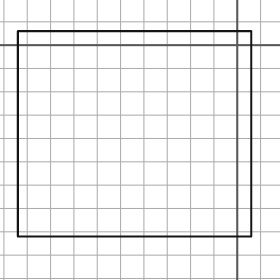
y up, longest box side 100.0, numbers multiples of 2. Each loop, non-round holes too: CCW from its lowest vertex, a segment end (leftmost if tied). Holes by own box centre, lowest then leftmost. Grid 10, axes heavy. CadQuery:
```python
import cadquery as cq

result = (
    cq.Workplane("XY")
    .moveTo(-94.0, -82.0)
    .lineTo(6.0, -82.0)
    .lineTo(6.0, 6.0)
    .lineTo(-94.0, 6.0)
    .close()
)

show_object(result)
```